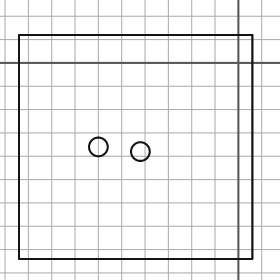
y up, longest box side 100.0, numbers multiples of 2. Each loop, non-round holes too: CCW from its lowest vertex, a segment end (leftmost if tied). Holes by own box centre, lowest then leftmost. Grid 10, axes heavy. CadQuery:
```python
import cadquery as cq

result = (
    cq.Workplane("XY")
    .moveTo(-94.0, -84.0)
    .lineTo(6.0, -84.0)
    .lineTo(6.0, 12.0)
    .lineTo(-94.0, 12.0)
    .close()
    .moveTo(-42.0, -38.0)
    .circle(4.0)
    .moveTo(-60.0, -36.0)
    .circle(4.0)
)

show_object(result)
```